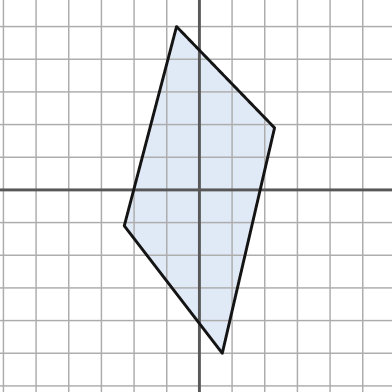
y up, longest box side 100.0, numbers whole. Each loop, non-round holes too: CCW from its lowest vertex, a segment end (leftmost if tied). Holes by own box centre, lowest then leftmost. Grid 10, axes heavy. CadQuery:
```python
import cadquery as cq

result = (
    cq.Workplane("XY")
    .moveTo(7.0, -50.0)
    .lineTo(23.0, 19.0)
    .lineTo(-7.0, 50.0)
    .lineTo(-23.0, -11.0)
    .close()
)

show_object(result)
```